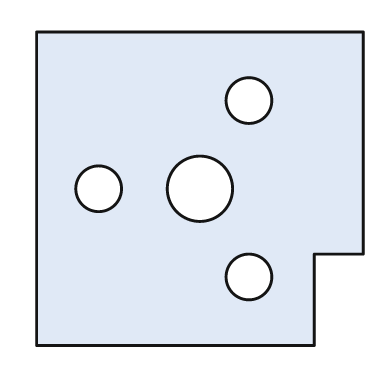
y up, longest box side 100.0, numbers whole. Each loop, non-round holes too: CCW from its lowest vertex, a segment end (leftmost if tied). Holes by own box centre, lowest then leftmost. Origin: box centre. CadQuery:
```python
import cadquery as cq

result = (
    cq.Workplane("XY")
    .moveTo(-50.0, -48.0)
    .lineTo(35.0, -48.0)
    .lineTo(35.0, -20.0)
    .lineTo(50.0, -20.0)
    .lineTo(50.0, 48.0)
    .lineTo(-50.0, 48.0)
    .close()
    .moveTo(15.0, -27.0)
    .circle(7.0)
    .moveTo(-31.0, 0.0)
    .circle(7.0)
    .moveTo(0.0, 0.0)
    .circle(10.0)
    .moveTo(15.0, 27.0)
    .circle(7.0)
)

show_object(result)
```